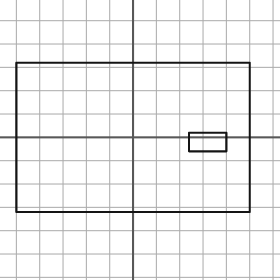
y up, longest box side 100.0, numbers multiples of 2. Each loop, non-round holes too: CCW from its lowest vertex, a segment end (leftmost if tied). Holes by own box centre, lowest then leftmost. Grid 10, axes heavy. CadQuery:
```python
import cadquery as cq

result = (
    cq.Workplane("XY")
    .moveTo(-50.0, -32.0)
    .lineTo(50.0, -32.0)
    .lineTo(50.0, 32.0)
    .lineTo(-50.0, 32.0)
    .close()
    .moveTo(24.0, -6.0)
    .lineTo(40.0, -6.0)
    .lineTo(40.0, 2.0)
    .lineTo(24.0, 2.0)
    .close()
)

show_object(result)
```